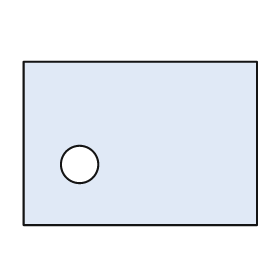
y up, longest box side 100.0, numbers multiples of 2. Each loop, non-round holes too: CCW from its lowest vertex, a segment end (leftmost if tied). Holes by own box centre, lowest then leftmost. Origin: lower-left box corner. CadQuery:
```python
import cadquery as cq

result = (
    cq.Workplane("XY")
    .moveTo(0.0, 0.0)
    .lineTo(100.0, 0.0)
    .lineTo(100.0, 70.0)
    .lineTo(0.0, 70.0)
    .close()
    .moveTo(24.0, 26.0)
    .circle(8.0)
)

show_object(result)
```